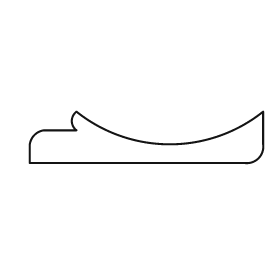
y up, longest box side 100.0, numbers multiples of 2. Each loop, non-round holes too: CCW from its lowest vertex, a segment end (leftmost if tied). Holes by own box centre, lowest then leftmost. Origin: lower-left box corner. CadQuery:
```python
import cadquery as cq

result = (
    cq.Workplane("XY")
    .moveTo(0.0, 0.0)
    .lineTo(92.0, 0.0)
    .threePointArc((98.0, 2.0), (100.0, 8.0))
    .lineTo(100.0, 22.0)
    .threePointArc((60.0, 8.0), (20.0, 22.0))
    .threePointArc((18.0, 18.0), (20.0, 14.0))
    .lineTo(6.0, 14.0)
    .threePointArc((2.0, 12.0), (0.0, 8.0))
    .close()
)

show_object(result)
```